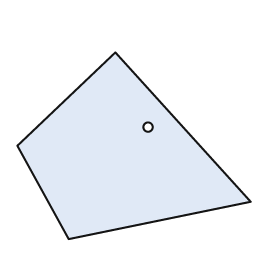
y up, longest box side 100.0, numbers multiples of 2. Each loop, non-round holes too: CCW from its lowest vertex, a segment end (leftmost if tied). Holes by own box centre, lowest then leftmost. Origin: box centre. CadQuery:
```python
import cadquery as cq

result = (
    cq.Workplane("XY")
    .moveTo(-28.0, -40.0)
    .lineTo(50.0, -24.0)
    .lineTo(-8.0, 40.0)
    .lineTo(-50.0, 0.0)
    .close()
    .moveTo(6.0, 8.0)
    .circle(2.0)
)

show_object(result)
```